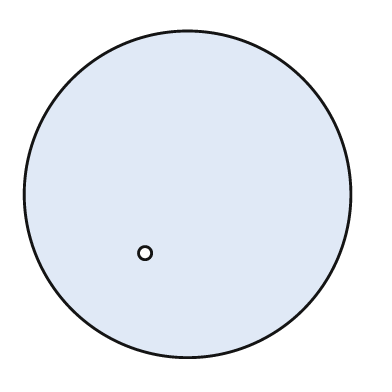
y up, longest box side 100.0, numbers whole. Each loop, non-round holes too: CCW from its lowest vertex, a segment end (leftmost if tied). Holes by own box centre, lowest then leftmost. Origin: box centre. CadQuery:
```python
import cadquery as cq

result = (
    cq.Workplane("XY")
    .moveTo(0.0, 0.0)
    .circle(50.0)
    .moveTo(-13.0, -18.0)
    .circle(2.0)
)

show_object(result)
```